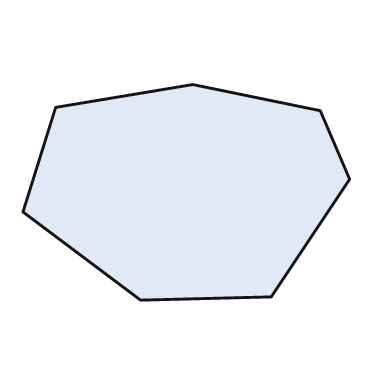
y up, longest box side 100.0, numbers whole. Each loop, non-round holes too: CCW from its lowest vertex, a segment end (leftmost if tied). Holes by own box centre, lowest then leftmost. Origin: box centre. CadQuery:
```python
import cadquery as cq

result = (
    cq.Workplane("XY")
    .moveTo(-14.0, -33.0)
    .lineTo(26.0, -32.0)
    .lineTo(50.0, 4.0)
    .lineTo(41.0, 25.0)
    .lineTo(2.0, 33.0)
    .lineTo(-40.0, 26.0)
    .lineTo(-50.0, -6.0)
    .close()
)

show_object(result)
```